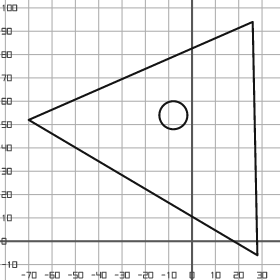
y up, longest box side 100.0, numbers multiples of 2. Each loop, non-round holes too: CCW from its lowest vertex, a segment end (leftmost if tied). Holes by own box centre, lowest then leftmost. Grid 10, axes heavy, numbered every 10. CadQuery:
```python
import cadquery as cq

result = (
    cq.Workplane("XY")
    .moveTo(28.0, -6.0)
    .lineTo(26.0, 94.0)
    .lineTo(-70.0, 52.0)
    .close()
    .moveTo(-8.0, 54.0)
    .circle(6.0)
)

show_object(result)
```